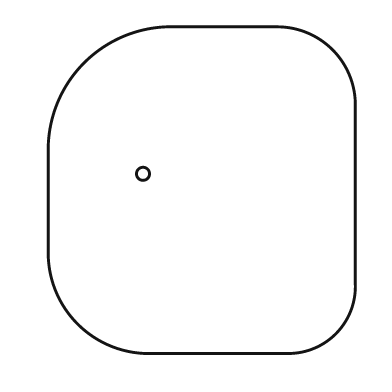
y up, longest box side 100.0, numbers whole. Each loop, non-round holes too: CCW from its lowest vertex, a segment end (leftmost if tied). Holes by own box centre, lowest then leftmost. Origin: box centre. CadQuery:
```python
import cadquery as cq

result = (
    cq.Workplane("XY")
    .moveTo(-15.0, -50.0)
    .lineTo(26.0, -50.0)
    .threePointArc((41.0, -44.0), (47.0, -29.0))
    .lineTo(47.0, 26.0)
    .threePointArc((40.0, 43.0), (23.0, 50.0))
    .lineTo(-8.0, 50.0)
    .threePointArc((-36.0, 39.0), (-47.0, 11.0))
    .lineTo(-47.0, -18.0)
    .threePointArc((-38.0, -41.0), (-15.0, -50.0))
    .close()
    .moveTo(-18.0, 5.0)
    .circle(2.0)
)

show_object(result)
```